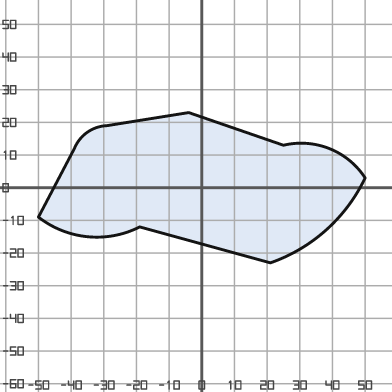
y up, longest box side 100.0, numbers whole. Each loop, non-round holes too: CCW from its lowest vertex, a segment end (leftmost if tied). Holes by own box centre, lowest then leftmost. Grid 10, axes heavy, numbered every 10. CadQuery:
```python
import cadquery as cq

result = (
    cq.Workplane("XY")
    .moveTo(21.0, -23.0)
    .threePointArc((38.0, -13.0), (50.0, 3.0))
    .threePointArc((39.0, 12.0), (25.0, 13.0))
    .lineTo(-4.0, 23.0)
    .lineTo(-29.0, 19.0)
    .threePointArc((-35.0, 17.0), (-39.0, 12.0))
    .lineTo(-50.0, -9.0)
    .threePointArc((-35.0, -15.0), (-19.0, -12.0))
    .close()
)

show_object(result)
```